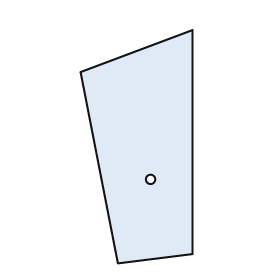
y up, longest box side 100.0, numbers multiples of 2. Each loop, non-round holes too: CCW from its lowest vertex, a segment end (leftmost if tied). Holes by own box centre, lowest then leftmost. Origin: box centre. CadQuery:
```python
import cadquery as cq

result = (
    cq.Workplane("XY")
    .moveTo(-8.0, -50.0)
    .lineTo(24.0, -46.0)
    .lineTo(24.0, 50.0)
    .lineTo(-24.0, 32.0)
    .close()
    .moveTo(6.0, -14.0)
    .circle(2.0)
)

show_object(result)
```